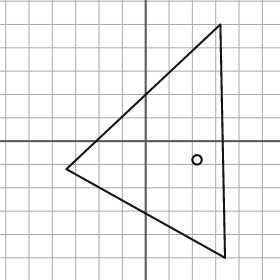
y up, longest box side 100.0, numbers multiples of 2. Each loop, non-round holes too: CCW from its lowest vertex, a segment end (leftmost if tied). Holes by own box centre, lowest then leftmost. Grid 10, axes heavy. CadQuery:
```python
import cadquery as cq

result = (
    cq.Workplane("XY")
    .moveTo(34.0, -50.0)
    .lineTo(32.0, 50.0)
    .lineTo(-34.0, -12.0)
    .close()
    .moveTo(22.0, -8.0)
    .circle(2.0)
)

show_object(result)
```